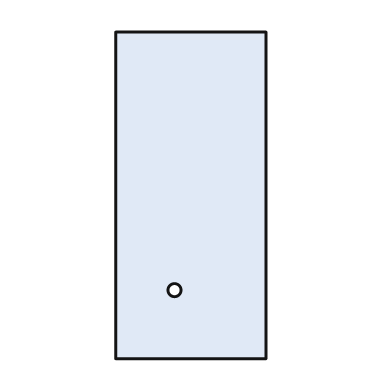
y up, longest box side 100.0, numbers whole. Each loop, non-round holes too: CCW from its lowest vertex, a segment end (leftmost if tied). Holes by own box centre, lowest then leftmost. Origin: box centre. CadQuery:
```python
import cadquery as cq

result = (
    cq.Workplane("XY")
    .moveTo(-23.0, -50.0)
    .lineTo(23.0, -50.0)
    .lineTo(23.0, 50.0)
    .lineTo(-23.0, 50.0)
    .close()
    .moveTo(-5.0, -29.0)
    .circle(2.0)
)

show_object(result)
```